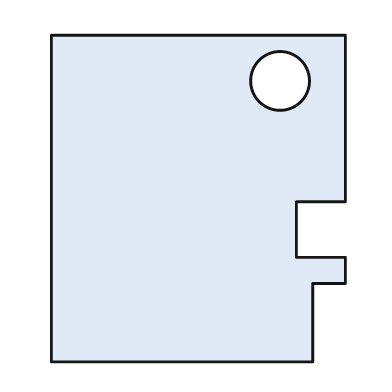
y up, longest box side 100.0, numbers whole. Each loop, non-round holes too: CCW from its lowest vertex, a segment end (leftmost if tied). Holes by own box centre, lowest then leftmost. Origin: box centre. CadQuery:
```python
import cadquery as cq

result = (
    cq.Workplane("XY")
    .moveTo(-45.0, -50.0)
    .lineTo(35.0, -50.0)
    .lineTo(35.0, -26.0)
    .lineTo(45.0, -26.0)
    .lineTo(45.0, -18.0)
    .lineTo(30.0, -18.0)
    .lineTo(30.0, -1.0)
    .lineTo(45.0, -1.0)
    .lineTo(45.0, 50.0)
    .lineTo(-45.0, 50.0)
    .close()
    .moveTo(25.0, 36.0)
    .circle(9.0)
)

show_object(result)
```